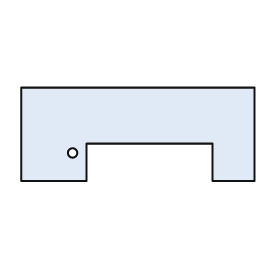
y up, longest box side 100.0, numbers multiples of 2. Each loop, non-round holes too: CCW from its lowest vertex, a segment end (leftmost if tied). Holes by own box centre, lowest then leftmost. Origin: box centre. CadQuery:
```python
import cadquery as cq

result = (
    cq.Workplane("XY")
    .moveTo(-50.0, -20.0)
    .lineTo(-22.0, -20.0)
    .lineTo(-22.0, -4.0)
    .lineTo(32.0, -4.0)
    .lineTo(32.0, -20.0)
    .lineTo(50.0, -20.0)
    .lineTo(50.0, 20.0)
    .lineTo(-50.0, 20.0)
    .close()
    .moveTo(-28.0, -8.0)
    .circle(2.0)
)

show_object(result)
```